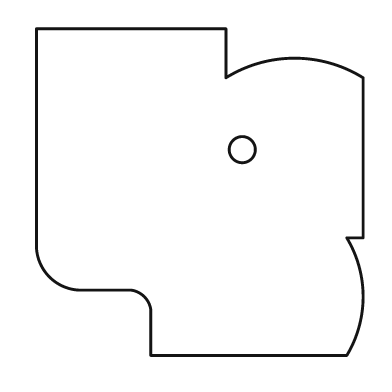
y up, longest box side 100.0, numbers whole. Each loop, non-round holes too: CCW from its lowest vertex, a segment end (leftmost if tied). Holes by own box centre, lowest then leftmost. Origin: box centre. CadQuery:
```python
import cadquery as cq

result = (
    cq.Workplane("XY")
    .moveTo(-15.0, -50.0)
    .lineTo(45.0, -50.0)
    .threePointArc((50.0, -32.0), (45.0, -14.0))
    .lineTo(50.0, -14.0)
    .lineTo(50.0, 35.0)
    .threePointArc((29.0, 41.0), (8.0, 35.0))
    .lineTo(8.0, 50.0)
    .lineTo(-50.0, 50.0)
    .lineTo(-50.0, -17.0)
    .threePointArc((-46.0, -26.0), (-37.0, -30.0))
    .lineTo(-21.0, -30.0)
    .threePointArc((-17.0, -32.0), (-15.0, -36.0))
    .close()
    .moveTo(13.0, 13.0)
    .circle(4.0)
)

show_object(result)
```